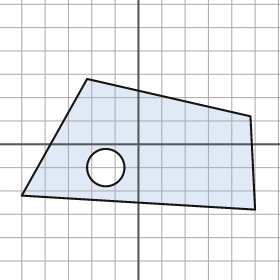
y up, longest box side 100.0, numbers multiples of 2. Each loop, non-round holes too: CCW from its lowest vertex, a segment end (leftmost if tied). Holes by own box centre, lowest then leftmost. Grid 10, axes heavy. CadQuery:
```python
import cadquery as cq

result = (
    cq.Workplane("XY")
    .moveTo(50.0, -28.0)
    .lineTo(48.0, 12.0)
    .lineTo(-22.0, 28.0)
    .lineTo(-50.0, -22.0)
    .close()
    .moveTo(-14.0, -10.0)
    .circle(8.0)
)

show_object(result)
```